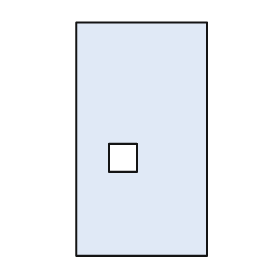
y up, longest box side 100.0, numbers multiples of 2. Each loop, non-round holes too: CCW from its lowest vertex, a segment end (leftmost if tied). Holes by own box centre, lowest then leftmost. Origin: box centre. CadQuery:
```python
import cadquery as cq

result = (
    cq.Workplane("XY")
    .moveTo(-28.0, -50.0)
    .lineTo(28.0, -50.0)
    .lineTo(28.0, 50.0)
    .lineTo(-28.0, 50.0)
    .close()
    .moveTo(-14.0, -14.0)
    .lineTo(-2.0, -14.0)
    .lineTo(-2.0, -2.0)
    .lineTo(-14.0, -2.0)
    .close()
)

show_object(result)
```